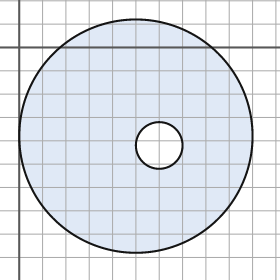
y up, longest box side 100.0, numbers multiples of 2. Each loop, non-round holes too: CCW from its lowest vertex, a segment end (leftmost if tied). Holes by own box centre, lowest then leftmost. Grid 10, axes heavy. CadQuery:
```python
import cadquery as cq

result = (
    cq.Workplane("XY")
    .moveTo(50.0, -38.0)
    .circle(50.0)
    .moveTo(60.0, -42.0)
    .circle(10.0)
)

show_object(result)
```